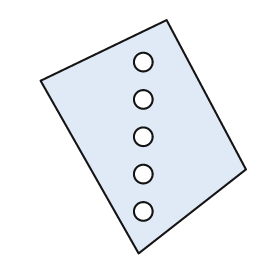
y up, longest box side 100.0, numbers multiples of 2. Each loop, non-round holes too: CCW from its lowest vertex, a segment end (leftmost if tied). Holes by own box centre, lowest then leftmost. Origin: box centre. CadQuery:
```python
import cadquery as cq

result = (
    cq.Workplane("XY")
    .moveTo(-2.0, -50.0)
    .lineTo(44.0, -14.0)
    .lineTo(10.0, 50.0)
    .lineTo(-44.0, 24.0)
    .close()
    .moveTo(0.0, -32.0)
    .circle(4.0)
    .moveTo(0.0, -16.0)
    .circle(4.0)
    .moveTo(0.0, 0.0)
    .circle(4.0)
    .moveTo(0.0, 16.0)
    .circle(4.0)
    .moveTo(0.0, 32.0)
    .circle(4.0)
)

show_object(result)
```